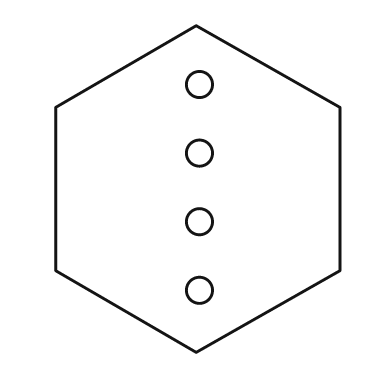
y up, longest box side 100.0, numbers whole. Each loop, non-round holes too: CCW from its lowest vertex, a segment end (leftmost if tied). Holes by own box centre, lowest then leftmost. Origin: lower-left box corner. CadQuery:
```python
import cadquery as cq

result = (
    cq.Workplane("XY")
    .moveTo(43.0, 0.0)
    .lineTo(87.0, 25.0)
    .lineTo(87.0, 75.0)
    .lineTo(43.0, 100.0)
    .lineTo(0.0, 75.0)
    .lineTo(0.0, 25.0)
    .close()
    .moveTo(44.0, 19.0)
    .circle(4.0)
    .moveTo(44.0, 40.0)
    .circle(4.0)
    .moveTo(44.0, 61.0)
    .circle(4.0)
    .moveTo(44.0, 82.0)
    .circle(4.0)
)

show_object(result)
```